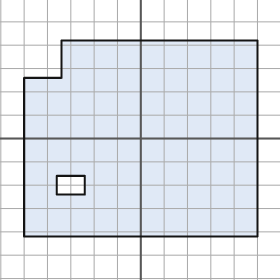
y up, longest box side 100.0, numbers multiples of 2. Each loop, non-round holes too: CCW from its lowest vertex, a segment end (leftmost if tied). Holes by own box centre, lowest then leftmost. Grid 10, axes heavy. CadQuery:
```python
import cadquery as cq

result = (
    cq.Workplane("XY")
    .moveTo(-50.0, -42.0)
    .lineTo(50.0, -42.0)
    .lineTo(50.0, 42.0)
    .lineTo(-34.0, 42.0)
    .lineTo(-34.0, 26.0)
    .lineTo(-50.0, 26.0)
    .close()
    .moveTo(-36.0, -24.0)
    .lineTo(-24.0, -24.0)
    .lineTo(-24.0, -16.0)
    .lineTo(-36.0, -16.0)
    .close()
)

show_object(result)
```